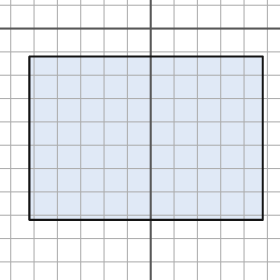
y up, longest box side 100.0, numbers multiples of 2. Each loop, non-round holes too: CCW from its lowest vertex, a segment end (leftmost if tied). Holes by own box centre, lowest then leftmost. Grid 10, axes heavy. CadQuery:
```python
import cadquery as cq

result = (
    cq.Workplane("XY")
    .moveTo(-52.0, -82.0)
    .lineTo(48.0, -82.0)
    .lineTo(48.0, -12.0)
    .lineTo(-52.0, -12.0)
    .close()
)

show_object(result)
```